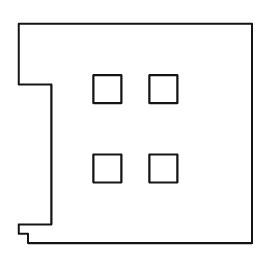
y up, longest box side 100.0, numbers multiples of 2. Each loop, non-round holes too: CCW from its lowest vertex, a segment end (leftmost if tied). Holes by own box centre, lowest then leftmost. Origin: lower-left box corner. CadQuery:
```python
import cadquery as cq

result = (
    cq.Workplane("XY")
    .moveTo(4.0, 0.0)
    .lineTo(100.0, 0.0)
    .lineTo(100.0, 94.0)
    .lineTo(0.0, 94.0)
    .lineTo(0.0, 68.0)
    .lineTo(14.0, 68.0)
    .lineTo(14.0, 8.0)
    .lineTo(0.0, 8.0)
    .lineTo(0.0, 4.0)
    .lineTo(4.0, 4.0)
    .close()
    .moveTo(32.0, 26.0)
    .lineTo(44.0, 26.0)
    .lineTo(44.0, 38.0)
    .lineTo(32.0, 38.0)
    .close()
    .moveTo(56.0, 26.0)
    .lineTo(68.0, 26.0)
    .lineTo(68.0, 38.0)
    .lineTo(56.0, 38.0)
    .close()
    .moveTo(32.0, 60.0)
    .lineTo(44.0, 60.0)
    .lineTo(44.0, 72.0)
    .lineTo(32.0, 72.0)
    .close()
    .moveTo(56.0, 60.0)
    .lineTo(68.0, 60.0)
    .lineTo(68.0, 72.0)
    .lineTo(56.0, 72.0)
    .close()
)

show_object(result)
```